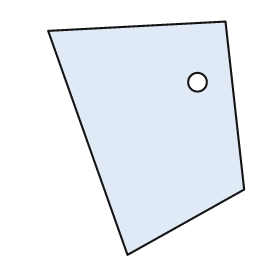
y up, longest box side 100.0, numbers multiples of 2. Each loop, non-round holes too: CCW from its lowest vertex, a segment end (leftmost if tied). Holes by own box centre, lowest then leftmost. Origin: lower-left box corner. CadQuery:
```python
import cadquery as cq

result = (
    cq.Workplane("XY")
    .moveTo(34.0, 0.0)
    .lineTo(84.0, 28.0)
    .lineTo(76.0, 100.0)
    .lineTo(0.0, 96.0)
    .close()
    .moveTo(64.0, 74.0)
    .circle(4.0)
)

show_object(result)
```